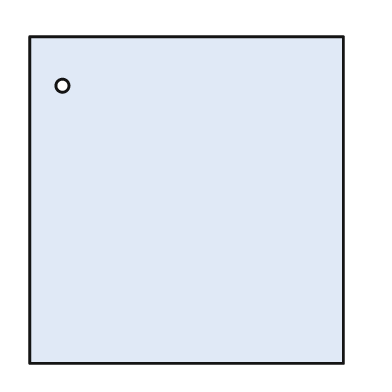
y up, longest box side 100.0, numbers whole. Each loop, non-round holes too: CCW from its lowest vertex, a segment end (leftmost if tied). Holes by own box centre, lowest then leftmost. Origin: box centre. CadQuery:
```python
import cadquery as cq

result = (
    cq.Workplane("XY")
    .moveTo(-48.0, -50.0)
    .lineTo(48.0, -50.0)
    .lineTo(48.0, 50.0)
    .lineTo(-48.0, 50.0)
    .close()
    .moveTo(-38.0, 35.0)
    .circle(2.0)
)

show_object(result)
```